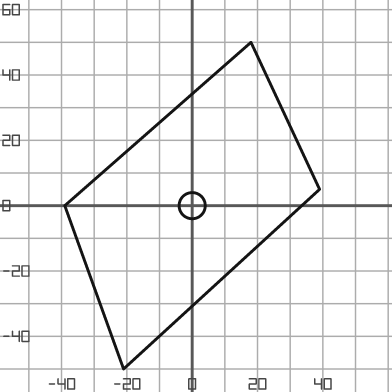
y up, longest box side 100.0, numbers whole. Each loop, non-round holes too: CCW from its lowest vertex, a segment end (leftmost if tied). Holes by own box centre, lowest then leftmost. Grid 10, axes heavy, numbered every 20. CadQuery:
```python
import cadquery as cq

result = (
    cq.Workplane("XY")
    .moveTo(-21.0, -50.0)
    .lineTo(39.0, 5.0)
    .lineTo(18.0, 50.0)
    .lineTo(-39.0, 0.0)
    .close()
    .moveTo(0.0, 0.0)
    .circle(4.0)
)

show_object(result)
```